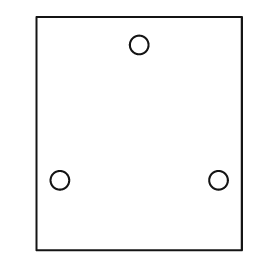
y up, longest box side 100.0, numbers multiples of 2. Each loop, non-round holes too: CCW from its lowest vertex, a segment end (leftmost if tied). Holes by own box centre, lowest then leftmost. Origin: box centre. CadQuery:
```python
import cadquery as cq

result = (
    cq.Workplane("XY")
    .moveTo(-44.0, -50.0)
    .lineTo(44.0, -50.0)
    .lineTo(44.0, 50.0)
    .lineTo(-44.0, 50.0)
    .close()
    .moveTo(-34.0, -20.0)
    .circle(4.0)
    .moveTo(34.0, -20.0)
    .circle(4.0)
    .moveTo(0.0, 38.0)
    .circle(4.0)
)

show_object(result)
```